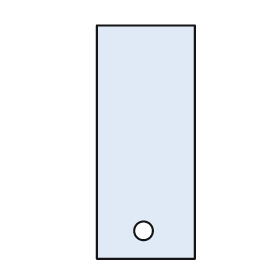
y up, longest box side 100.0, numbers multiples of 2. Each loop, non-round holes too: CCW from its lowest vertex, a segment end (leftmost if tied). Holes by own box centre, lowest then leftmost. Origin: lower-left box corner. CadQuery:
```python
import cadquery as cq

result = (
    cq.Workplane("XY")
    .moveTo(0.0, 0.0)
    .lineTo(42.0, 0.0)
    .lineTo(42.0, 100.0)
    .lineTo(0.0, 100.0)
    .close()
    .moveTo(20.0, 12.0)
    .circle(4.0)
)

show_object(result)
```